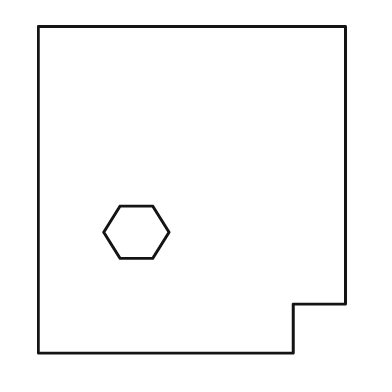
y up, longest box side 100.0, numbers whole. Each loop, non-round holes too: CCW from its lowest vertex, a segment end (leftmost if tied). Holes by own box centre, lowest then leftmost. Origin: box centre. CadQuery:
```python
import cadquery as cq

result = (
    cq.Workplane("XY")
    .moveTo(-47.0, -50.0)
    .lineTo(31.0, -50.0)
    .lineTo(31.0, -35.0)
    .lineTo(47.0, -35.0)
    .lineTo(47.0, 50.0)
    .lineTo(-47.0, 50.0)
    .close()
    .moveTo(-22.0, -21.0)
    .lineTo(-12.0, -21.0)
    .lineTo(-7.0, -13.0)
    .lineTo(-12.0, -5.0)
    .lineTo(-22.0, -5.0)
    .lineTo(-27.0, -13.0)
    .close()
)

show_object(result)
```